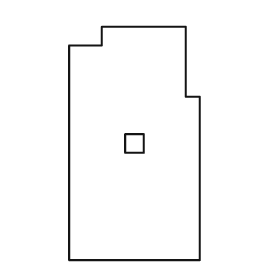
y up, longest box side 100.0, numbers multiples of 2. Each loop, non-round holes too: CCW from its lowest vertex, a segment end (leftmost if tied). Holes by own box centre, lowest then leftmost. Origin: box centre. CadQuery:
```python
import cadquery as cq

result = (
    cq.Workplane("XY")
    .moveTo(-28.0, -50.0)
    .lineTo(28.0, -50.0)
    .lineTo(28.0, 20.0)
    .lineTo(22.0, 20.0)
    .lineTo(22.0, 50.0)
    .lineTo(-14.0, 50.0)
    .lineTo(-14.0, 42.0)
    .lineTo(-28.0, 42.0)
    .close()
    .moveTo(-4.0, -4.0)
    .lineTo(4.0, -4.0)
    .lineTo(4.0, 4.0)
    .lineTo(-4.0, 4.0)
    .close()
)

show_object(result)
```